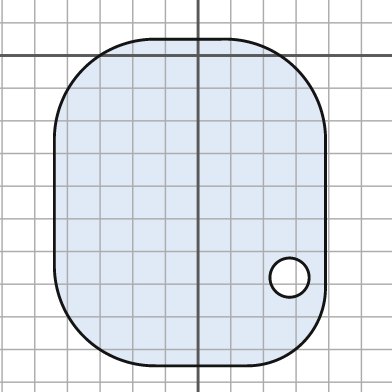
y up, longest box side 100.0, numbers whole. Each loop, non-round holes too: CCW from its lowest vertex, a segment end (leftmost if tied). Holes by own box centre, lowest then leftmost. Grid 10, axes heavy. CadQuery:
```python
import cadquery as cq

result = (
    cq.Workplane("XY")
    .moveTo(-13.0, -95.0)
    .lineTo(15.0, -95.0)
    .threePointArc((32.0, -88.0), (39.0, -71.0))
    .lineTo(39.0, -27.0)
    .threePointArc((30.0, -4.0), (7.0, 5.0))
    .lineTo(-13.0, 5.0)
    .threePointArc((-35.0, -4.0), (-44.0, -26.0))
    .lineTo(-44.0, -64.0)
    .threePointArc((-35.0, -86.0), (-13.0, -95.0))
    .close()
    .moveTo(28.0, -68.0)
    .circle(6.0)
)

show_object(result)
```